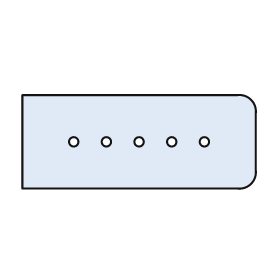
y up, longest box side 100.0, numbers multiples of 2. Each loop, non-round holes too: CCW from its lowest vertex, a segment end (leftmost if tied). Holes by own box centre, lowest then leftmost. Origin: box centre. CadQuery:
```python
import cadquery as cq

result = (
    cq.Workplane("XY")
    .moveTo(-50.0, -20.0)
    .lineTo(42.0, -20.0)
    .threePointArc((48.0, -18.0), (50.0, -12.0))
    .lineTo(50.0, 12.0)
    .threePointArc((48.0, 18.0), (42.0, 20.0))
    .lineTo(-50.0, 20.0)
    .close()
    .moveTo(-28.0, 0.0)
    .circle(2.0)
    .moveTo(-14.0, 0.0)
    .circle(2.0)
    .moveTo(0.0, 0.0)
    .circle(2.0)
    .moveTo(14.0, 0.0)
    .circle(2.0)
    .moveTo(28.0, 0.0)
    .circle(2.0)
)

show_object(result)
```